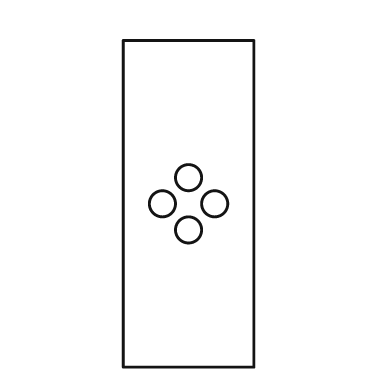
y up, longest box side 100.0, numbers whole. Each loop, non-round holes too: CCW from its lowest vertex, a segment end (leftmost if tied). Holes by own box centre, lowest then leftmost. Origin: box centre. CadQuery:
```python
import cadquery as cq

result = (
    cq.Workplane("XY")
    .moveTo(-20.0, -50.0)
    .lineTo(20.0, -50.0)
    .lineTo(20.0, 50.0)
    .lineTo(-20.0, 50.0)
    .close()
    .moveTo(0.0, -8.0)
    .circle(4.0)
    .moveTo(-8.0, 0.0)
    .circle(4.0)
    .moveTo(8.0, 0.0)
    .circle(4.0)
    .moveTo(0.0, 8.0)
    .circle(4.0)
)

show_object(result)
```